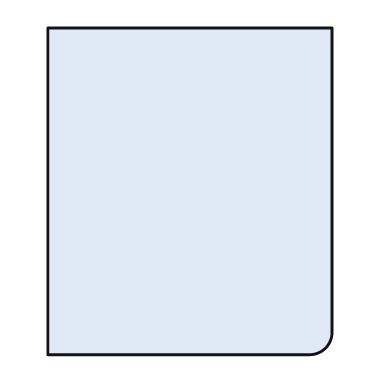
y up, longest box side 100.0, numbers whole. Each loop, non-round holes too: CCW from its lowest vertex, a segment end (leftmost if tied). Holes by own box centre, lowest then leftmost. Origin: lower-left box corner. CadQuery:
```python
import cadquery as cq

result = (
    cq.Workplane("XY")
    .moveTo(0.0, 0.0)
    .lineTo(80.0, 0.0)
    .threePointArc((85.0, 2.0), (87.0, 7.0))
    .lineTo(87.0, 100.0)
    .lineTo(0.0, 100.0)
    .close()
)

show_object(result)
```